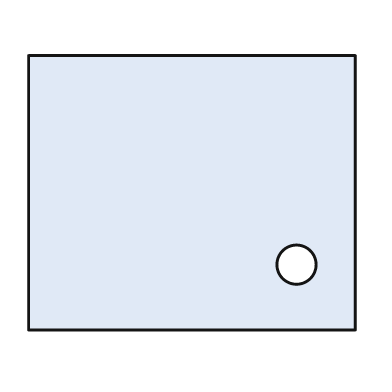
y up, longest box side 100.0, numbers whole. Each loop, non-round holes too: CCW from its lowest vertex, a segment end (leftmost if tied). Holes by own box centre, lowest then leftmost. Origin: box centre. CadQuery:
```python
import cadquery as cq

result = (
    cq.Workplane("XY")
    .moveTo(-50.0, -42.0)
    .lineTo(50.0, -42.0)
    .lineTo(50.0, 42.0)
    .lineTo(-50.0, 42.0)
    .close()
    .moveTo(32.0, -22.0)
    .circle(6.0)
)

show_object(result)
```